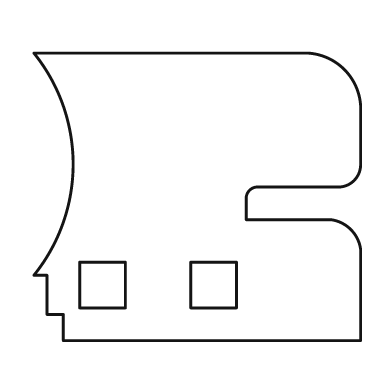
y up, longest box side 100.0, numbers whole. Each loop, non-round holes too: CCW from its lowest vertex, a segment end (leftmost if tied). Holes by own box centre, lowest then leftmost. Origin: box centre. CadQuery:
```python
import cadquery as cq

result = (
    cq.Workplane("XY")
    .moveTo(-41.0, -44.0)
    .lineTo(50.0, -44.0)
    .lineTo(50.0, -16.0)
    .threePointArc((47.0, -10.0), (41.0, -7.0))
    .lineTo(15.0, -7.0)
    .lineTo(15.0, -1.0)
    .threePointArc((16.0, 2.0), (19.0, 3.0))
    .lineTo(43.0, 3.0)
    .threePointArc((48.0, 5.0), (50.0, 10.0))
    .lineTo(50.0, 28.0)
    .threePointArc((45.0, 39.0), (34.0, 44.0))
    .lineTo(-50.0, 44.0)
    .threePointArc((-38.0, 10.0), (-50.0, -24.0))
    .lineTo(-46.0, -24.0)
    .lineTo(-46.0, -36.0)
    .lineTo(-41.0, -36.0)
    .close()
    .moveTo(-36.0, -34.0)
    .lineTo(-22.0, -34.0)
    .lineTo(-22.0, -20.0)
    .lineTo(-36.0, -20.0)
    .close()
    .moveTo(-2.0, -34.0)
    .lineTo(12.0, -34.0)
    .lineTo(12.0, -20.0)
    .lineTo(-2.0, -20.0)
    .close()
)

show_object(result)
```